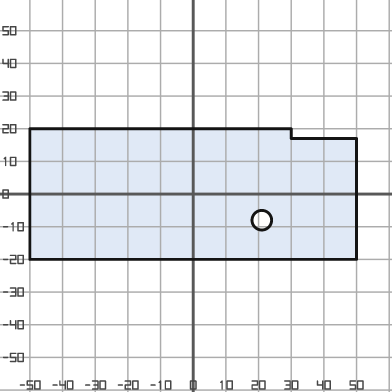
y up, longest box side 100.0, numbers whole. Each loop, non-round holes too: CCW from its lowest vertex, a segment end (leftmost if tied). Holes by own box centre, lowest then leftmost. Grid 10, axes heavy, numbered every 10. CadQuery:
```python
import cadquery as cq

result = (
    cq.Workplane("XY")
    .moveTo(-50.0, -20.0)
    .lineTo(50.0, -20.0)
    .lineTo(50.0, 17.0)
    .lineTo(30.0, 17.0)
    .lineTo(30.0, 20.0)
    .lineTo(-50.0, 20.0)
    .close()
    .moveTo(21.0, -8.0)
    .circle(3.0)
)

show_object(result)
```